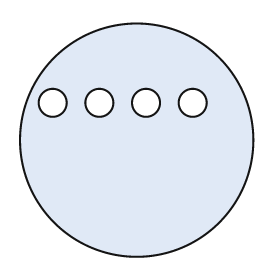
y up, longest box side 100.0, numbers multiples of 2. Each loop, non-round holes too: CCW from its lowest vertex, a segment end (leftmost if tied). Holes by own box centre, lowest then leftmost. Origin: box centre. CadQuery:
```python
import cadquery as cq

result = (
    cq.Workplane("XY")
    .moveTo(0.0, 0.0)
    .circle(50.0)
    .moveTo(-36.0, 16.0)
    .circle(6.0)
    .moveTo(-16.0, 16.0)
    .circle(6.0)
    .moveTo(4.0, 16.0)
    .circle(6.0)
    .moveTo(24.0, 16.0)
    .circle(6.0)
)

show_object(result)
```